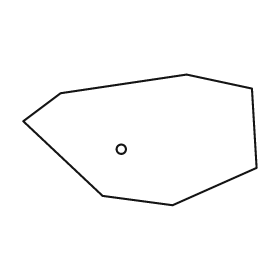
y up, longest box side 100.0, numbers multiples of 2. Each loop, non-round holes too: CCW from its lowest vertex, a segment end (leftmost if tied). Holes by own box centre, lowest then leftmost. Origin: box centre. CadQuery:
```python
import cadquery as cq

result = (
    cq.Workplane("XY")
    .moveTo(14.0, -28.0)
    .lineTo(50.0, -12.0)
    .lineTo(48.0, 22.0)
    .lineTo(20.0, 28.0)
    .lineTo(-34.0, 20.0)
    .lineTo(-50.0, 8.0)
    .lineTo(-16.0, -24.0)
    .close()
    .moveTo(-8.0, -4.0)
    .circle(2.0)
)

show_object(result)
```